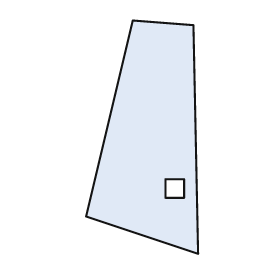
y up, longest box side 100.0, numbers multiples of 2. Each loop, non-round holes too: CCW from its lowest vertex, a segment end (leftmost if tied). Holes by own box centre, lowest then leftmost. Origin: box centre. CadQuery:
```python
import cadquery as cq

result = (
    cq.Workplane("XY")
    .moveTo(24.0, -50.0)
    .lineTo(22.0, 48.0)
    .lineTo(-4.0, 50.0)
    .lineTo(-24.0, -34.0)
    .close()
    .moveTo(10.0, -26.0)
    .lineTo(18.0, -26.0)
    .lineTo(18.0, -18.0)
    .lineTo(10.0, -18.0)
    .close()
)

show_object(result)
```